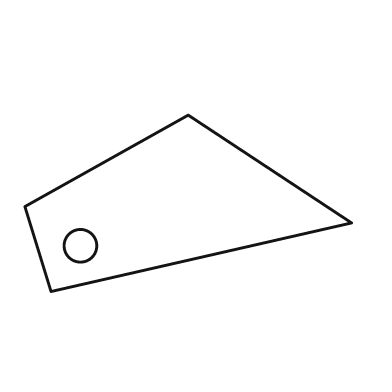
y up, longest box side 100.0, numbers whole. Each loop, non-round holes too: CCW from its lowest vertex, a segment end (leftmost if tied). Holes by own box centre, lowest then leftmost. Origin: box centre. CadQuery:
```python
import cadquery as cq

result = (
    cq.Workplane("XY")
    .moveTo(-42.0, -27.0)
    .lineTo(50.0, -6.0)
    .lineTo(0.0, 27.0)
    .lineTo(-50.0, -1.0)
    .close()
    .moveTo(-33.0, -13.0)
    .circle(5.0)
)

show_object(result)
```